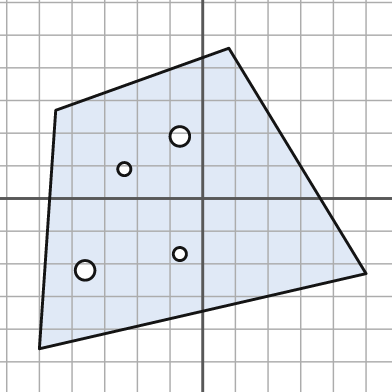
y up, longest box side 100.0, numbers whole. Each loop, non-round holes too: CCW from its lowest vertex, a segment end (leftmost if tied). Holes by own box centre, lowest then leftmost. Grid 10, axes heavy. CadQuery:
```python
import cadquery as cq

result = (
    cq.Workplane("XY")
    .moveTo(-50.0, -46.0)
    .lineTo(50.0, -23.0)
    .lineTo(8.0, 46.0)
    .lineTo(-45.0, 27.0)
    .close()
    .moveTo(-36.0, -22.0)
    .circle(3.0)
    .moveTo(-7.0, -17.0)
    .circle(2.0)
    .moveTo(-24.0, 9.0)
    .circle(2.0)
    .moveTo(-7.0, 19.0)
    .circle(3.0)
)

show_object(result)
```